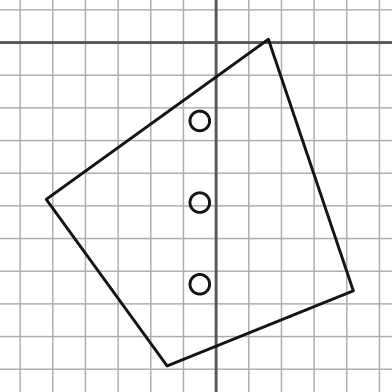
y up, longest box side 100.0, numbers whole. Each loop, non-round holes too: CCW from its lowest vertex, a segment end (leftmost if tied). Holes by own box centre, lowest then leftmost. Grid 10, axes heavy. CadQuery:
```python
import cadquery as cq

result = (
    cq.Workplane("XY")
    .moveTo(-15.0, -99.0)
    .lineTo(42.0, -76.0)
    .lineTo(16.0, 1.0)
    .lineTo(-52.0, -48.0)
    .close()
    .moveTo(-5.0, -74.0)
    .circle(3.0)
    .moveTo(-5.0, -49.0)
    .circle(3.0)
    .moveTo(-5.0, -24.0)
    .circle(3.0)
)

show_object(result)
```